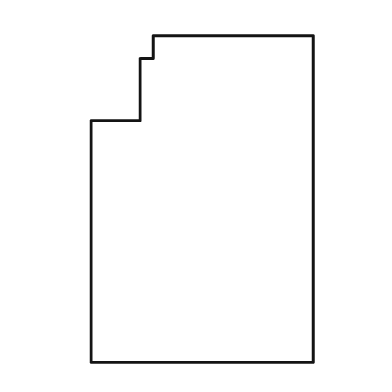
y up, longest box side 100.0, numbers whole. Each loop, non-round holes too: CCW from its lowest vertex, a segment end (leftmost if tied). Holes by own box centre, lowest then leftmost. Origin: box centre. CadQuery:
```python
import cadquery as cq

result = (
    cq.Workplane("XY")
    .moveTo(-34.0, -50.0)
    .lineTo(34.0, -50.0)
    .lineTo(34.0, 50.0)
    .lineTo(-15.0, 50.0)
    .lineTo(-15.0, 43.0)
    .lineTo(-19.0, 43.0)
    .lineTo(-19.0, 24.0)
    .lineTo(-34.0, 24.0)
    .close()
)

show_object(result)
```